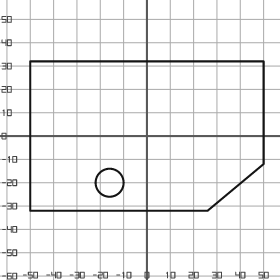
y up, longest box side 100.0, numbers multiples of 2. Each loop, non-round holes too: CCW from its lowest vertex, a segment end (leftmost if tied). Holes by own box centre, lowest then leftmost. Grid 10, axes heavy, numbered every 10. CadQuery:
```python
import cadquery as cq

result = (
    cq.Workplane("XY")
    .moveTo(-50.0, -32.0)
    .lineTo(26.0, -32.0)
    .lineTo(50.0, -12.0)
    .lineTo(50.0, 32.0)
    .lineTo(-50.0, 32.0)
    .close()
    .moveTo(-16.0, -20.0)
    .circle(6.0)
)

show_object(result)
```